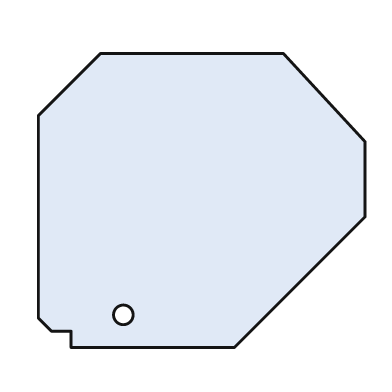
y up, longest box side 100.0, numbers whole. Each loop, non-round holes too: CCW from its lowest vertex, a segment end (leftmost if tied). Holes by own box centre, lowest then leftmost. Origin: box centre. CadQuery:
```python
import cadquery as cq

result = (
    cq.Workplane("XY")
    .moveTo(-40.0, -45.0)
    .lineTo(10.0, -45.0)
    .lineTo(50.0, -5.0)
    .lineTo(50.0, 18.0)
    .lineTo(25.0, 45.0)
    .lineTo(-31.0, 45.0)
    .lineTo(-50.0, 26.0)
    .lineTo(-50.0, -36.0)
    .lineTo(-46.0, -40.0)
    .lineTo(-40.0, -40.0)
    .close()
    .moveTo(-24.0, -35.0)
    .circle(3.0)
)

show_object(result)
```